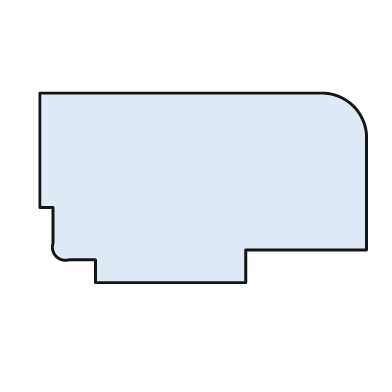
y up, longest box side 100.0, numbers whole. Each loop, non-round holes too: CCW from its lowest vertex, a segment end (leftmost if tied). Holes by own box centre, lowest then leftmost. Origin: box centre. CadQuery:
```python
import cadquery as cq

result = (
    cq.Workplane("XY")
    .moveTo(-33.0, -29.0)
    .lineTo(13.0, -29.0)
    .lineTo(13.0, -19.0)
    .lineTo(50.0, -19.0)
    .lineTo(50.0, 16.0)
    .threePointArc((46.0, 25.0), (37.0, 29.0))
    .lineTo(-50.0, 29.0)
    .lineTo(-50.0, -6.0)
    .lineTo(-46.0, -6.0)
    .lineTo(-46.0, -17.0)
    .threePointArc((-45.0, -21.0), (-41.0, -22.0))
    .lineTo(-33.0, -22.0)
    .close()
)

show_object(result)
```